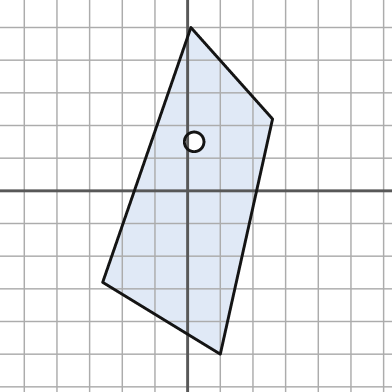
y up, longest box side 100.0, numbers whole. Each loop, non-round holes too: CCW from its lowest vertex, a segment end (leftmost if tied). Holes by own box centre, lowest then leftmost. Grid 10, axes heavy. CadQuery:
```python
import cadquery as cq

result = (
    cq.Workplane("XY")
    .moveTo(10.0, -50.0)
    .lineTo(26.0, 22.0)
    .lineTo(1.0, 50.0)
    .lineTo(-26.0, -28.0)
    .close()
    .moveTo(2.0, 15.0)
    .circle(3.0)
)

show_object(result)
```